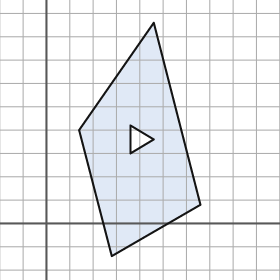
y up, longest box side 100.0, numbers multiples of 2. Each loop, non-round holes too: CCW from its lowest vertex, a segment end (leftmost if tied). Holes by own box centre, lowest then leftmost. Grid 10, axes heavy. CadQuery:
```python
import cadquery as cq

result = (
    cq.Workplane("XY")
    .moveTo(28.0, -14.0)
    .lineTo(66.0, 8.0)
    .lineTo(46.0, 86.0)
    .lineTo(14.0, 40.0)
    .close()
    .moveTo(36.0, 30.0)
    .lineTo(46.0, 36.0)
    .lineTo(36.0, 42.0)
    .close()
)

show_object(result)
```